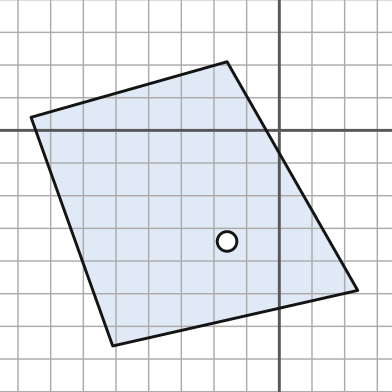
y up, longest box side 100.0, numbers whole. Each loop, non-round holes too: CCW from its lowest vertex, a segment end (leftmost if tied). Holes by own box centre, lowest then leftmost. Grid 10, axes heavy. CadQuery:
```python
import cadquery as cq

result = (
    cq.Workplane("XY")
    .moveTo(-51.0, -66.0)
    .lineTo(24.0, -49.0)
    .lineTo(-16.0, 21.0)
    .lineTo(-76.0, 4.0)
    .close()
    .moveTo(-16.0, -34.0)
    .circle(3.0)
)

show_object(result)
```